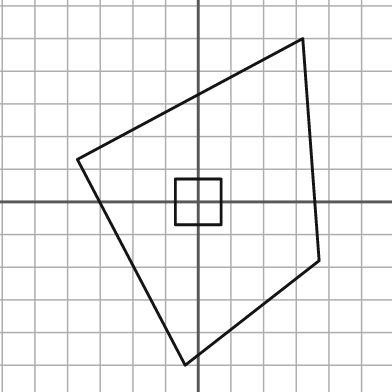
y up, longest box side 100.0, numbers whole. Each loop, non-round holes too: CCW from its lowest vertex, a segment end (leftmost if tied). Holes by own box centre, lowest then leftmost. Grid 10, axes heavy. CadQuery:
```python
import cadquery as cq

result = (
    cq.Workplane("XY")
    .moveTo(-4.0, -50.0)
    .lineTo(37.0, -18.0)
    .lineTo(32.0, 50.0)
    .lineTo(-37.0, 13.0)
    .close()
    .moveTo(-7.0, -7.0)
    .lineTo(7.0, -7.0)
    .lineTo(7.0, 7.0)
    .lineTo(-7.0, 7.0)
    .close()
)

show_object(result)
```